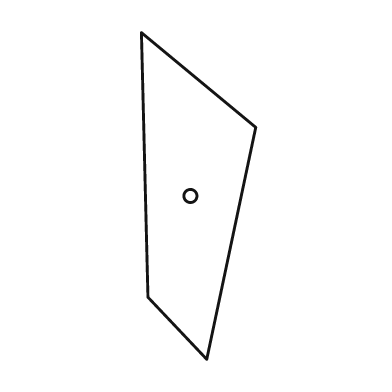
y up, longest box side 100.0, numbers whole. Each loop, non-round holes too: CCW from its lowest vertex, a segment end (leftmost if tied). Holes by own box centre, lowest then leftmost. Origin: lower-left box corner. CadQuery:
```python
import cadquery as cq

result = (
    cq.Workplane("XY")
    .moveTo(20.0, 0.0)
    .lineTo(35.0, 71.0)
    .lineTo(0.0, 100.0)
    .lineTo(2.0, 19.0)
    .close()
    .moveTo(15.0, 50.0)
    .circle(2.0)
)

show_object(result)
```